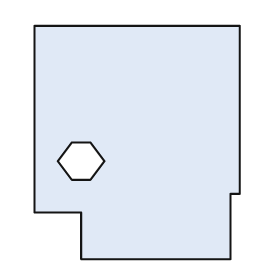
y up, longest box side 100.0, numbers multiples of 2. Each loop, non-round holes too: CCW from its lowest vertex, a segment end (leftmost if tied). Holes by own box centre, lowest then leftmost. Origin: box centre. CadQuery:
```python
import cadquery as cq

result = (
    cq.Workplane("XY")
    .moveTo(-24.0, -50.0)
    .lineTo(40.0, -50.0)
    .lineTo(40.0, -22.0)
    .lineTo(44.0, -22.0)
    .lineTo(44.0, 50.0)
    .lineTo(-44.0, 50.0)
    .lineTo(-44.0, -30.0)
    .lineTo(-24.0, -30.0)
    .close()
    .moveTo(-28.0, -16.0)
    .lineTo(-20.0, -16.0)
    .lineTo(-14.0, -8.0)
    .lineTo(-20.0, 0.0)
    .lineTo(-28.0, 0.0)
    .lineTo(-34.0, -8.0)
    .close()
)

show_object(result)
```